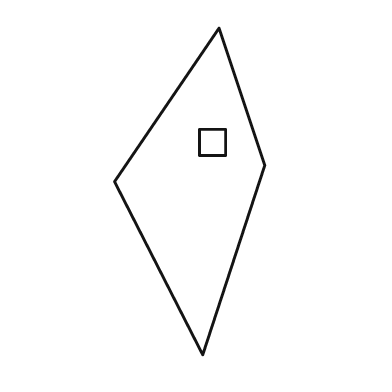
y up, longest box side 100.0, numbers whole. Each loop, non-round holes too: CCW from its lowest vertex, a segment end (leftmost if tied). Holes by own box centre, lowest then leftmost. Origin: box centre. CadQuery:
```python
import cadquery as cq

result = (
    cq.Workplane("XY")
    .moveTo(4.0, -50.0)
    .lineTo(23.0, 8.0)
    .lineTo(9.0, 50.0)
    .lineTo(-23.0, 3.0)
    .close()
    .moveTo(3.0, 11.0)
    .lineTo(11.0, 11.0)
    .lineTo(11.0, 19.0)
    .lineTo(3.0, 19.0)
    .close()
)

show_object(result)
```